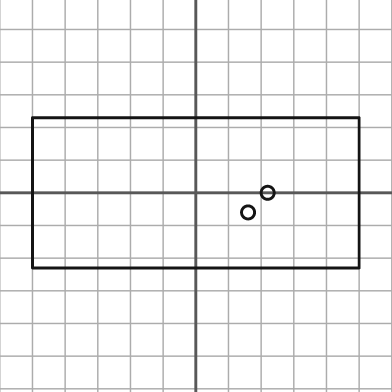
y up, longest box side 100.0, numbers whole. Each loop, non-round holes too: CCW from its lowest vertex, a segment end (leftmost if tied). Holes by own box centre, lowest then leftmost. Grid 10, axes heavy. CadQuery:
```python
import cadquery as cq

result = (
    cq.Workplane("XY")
    .moveTo(-50.0, -23.0)
    .lineTo(50.0, -23.0)
    .lineTo(50.0, 23.0)
    .lineTo(-50.0, 23.0)
    .close()
    .moveTo(16.0, -6.0)
    .circle(2.0)
    .moveTo(22.0, 0.0)
    .circle(2.0)
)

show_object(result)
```